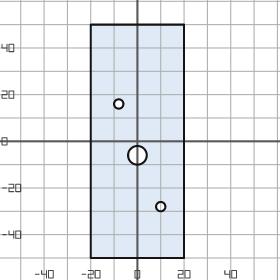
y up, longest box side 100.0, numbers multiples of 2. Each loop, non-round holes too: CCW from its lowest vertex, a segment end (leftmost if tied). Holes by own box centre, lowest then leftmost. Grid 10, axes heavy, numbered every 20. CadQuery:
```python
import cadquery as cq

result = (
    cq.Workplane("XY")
    .moveTo(-20.0, -50.0)
    .lineTo(20.0, -50.0)
    .lineTo(20.0, 50.0)
    .lineTo(-20.0, 50.0)
    .close()
    .moveTo(10.0, -28.0)
    .circle(2.0)
    .moveTo(0.0, -6.0)
    .circle(4.0)
    .moveTo(-8.0, 16.0)
    .circle(2.0)
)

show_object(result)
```